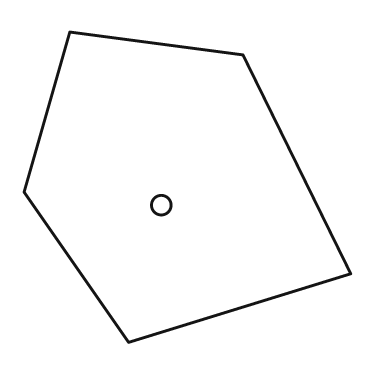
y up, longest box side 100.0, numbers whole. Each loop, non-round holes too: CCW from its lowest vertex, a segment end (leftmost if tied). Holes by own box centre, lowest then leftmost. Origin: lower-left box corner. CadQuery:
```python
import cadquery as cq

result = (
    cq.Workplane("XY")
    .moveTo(32.0, 0.0)
    .lineTo(100.0, 21.0)
    .lineTo(67.0, 88.0)
    .lineTo(14.0, 95.0)
    .lineTo(0.0, 46.0)
    .close()
    .moveTo(42.0, 42.0)
    .circle(3.0)
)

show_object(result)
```